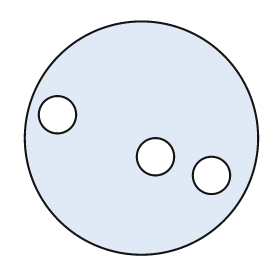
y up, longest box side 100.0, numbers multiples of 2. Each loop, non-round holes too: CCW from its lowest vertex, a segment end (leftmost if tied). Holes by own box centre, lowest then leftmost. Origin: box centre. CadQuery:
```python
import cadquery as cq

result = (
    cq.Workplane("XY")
    .moveTo(0.0, 0.0)
    .circle(50.0)
    .moveTo(30.0, -16.0)
    .circle(8.0)
    .moveTo(6.0, -8.0)
    .circle(8.0)
    .moveTo(-36.0, 10.0)
    .circle(8.0)
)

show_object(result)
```